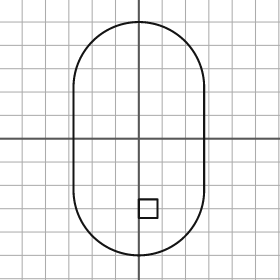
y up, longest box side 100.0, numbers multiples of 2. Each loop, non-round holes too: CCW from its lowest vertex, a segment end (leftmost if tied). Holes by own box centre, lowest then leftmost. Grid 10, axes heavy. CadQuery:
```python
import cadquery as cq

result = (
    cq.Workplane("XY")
    .moveTo(-28.0, -22.0)
    .threePointArc((0.0, -50.0), (28.0, -22.0))
    .lineTo(28.0, 22.0)
    .threePointArc((0.0, 50.0), (-28.0, 22.0))
    .close()
    .moveTo(0.0, -34.0)
    .lineTo(8.0, -34.0)
    .lineTo(8.0, -26.0)
    .lineTo(0.0, -26.0)
    .close()
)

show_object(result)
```